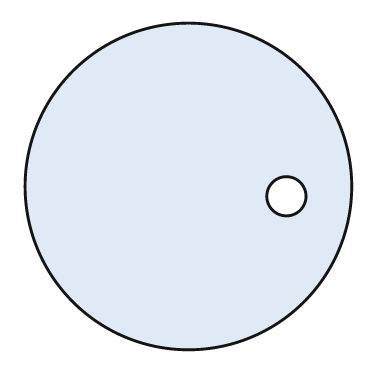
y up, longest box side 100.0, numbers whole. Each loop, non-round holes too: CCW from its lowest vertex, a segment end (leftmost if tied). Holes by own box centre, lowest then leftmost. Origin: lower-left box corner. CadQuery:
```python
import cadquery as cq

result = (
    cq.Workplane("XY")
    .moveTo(50.0, 50.0)
    .circle(50.0)
    .moveTo(80.0, 47.0)
    .circle(6.0)
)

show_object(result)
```